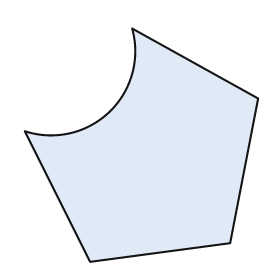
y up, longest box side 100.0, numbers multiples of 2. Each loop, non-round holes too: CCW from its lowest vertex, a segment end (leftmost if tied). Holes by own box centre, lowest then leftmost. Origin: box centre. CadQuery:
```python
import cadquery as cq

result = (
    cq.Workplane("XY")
    .moveTo(-22.0, -50.0)
    .lineTo(38.0, -42.0)
    .lineTo(50.0, 20.0)
    .lineTo(-4.0, 50.0)
    .threePointArc((-14.0, 14.0), (-50.0, 6.0))
    .close()
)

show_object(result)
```